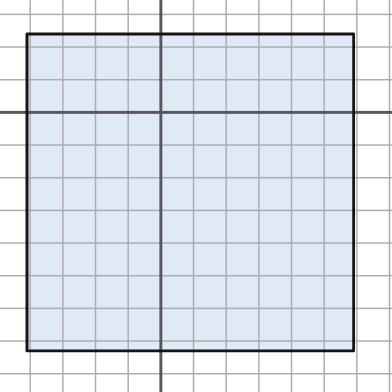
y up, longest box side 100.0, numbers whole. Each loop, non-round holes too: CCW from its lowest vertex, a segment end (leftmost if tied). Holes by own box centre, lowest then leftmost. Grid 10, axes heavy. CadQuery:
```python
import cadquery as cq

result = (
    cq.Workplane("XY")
    .moveTo(-41.0, -73.0)
    .lineTo(59.0, -73.0)
    .lineTo(59.0, 24.0)
    .lineTo(-41.0, 24.0)
    .close()
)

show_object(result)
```